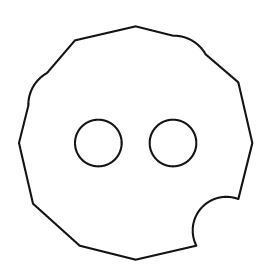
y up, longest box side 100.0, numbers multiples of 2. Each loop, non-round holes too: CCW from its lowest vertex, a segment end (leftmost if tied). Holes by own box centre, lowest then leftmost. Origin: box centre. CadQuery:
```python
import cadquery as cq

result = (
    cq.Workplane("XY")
    .moveTo(0.0, -50.0)
    .lineTo(26.0, -44.0)
    .threePointArc((28.0, -28.0), (44.0, -24.0))
    .lineTo(50.0, 0.0)
    .lineTo(44.0, 26.0)
    .lineTo(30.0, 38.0)
    .threePointArc((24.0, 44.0), (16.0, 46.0))
    .lineTo(0.0, 50.0)
    .lineTo(-26.0, 44.0)
    .lineTo(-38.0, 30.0)
    .threePointArc((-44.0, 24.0), (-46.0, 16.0))
    .lineTo(-50.0, 0.0)
    .lineTo(-44.0, -26.0)
    .lineTo(-24.0, -44.0)
    .close()
    .moveTo(-16.0, 0.0)
    .circle(10.0)
    .moveTo(16.0, 0.0)
    .circle(10.0)
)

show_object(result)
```